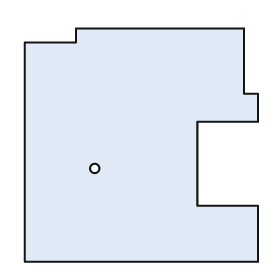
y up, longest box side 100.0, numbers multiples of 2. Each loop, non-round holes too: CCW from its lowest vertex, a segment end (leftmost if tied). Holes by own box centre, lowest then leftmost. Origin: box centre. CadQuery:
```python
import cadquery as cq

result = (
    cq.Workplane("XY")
    .moveTo(-50.0, -50.0)
    .lineTo(50.0, -50.0)
    .lineTo(50.0, -26.0)
    .lineTo(24.0, -26.0)
    .lineTo(24.0, 10.0)
    .lineTo(50.0, 10.0)
    .lineTo(50.0, 22.0)
    .lineTo(44.0, 22.0)
    .lineTo(44.0, 50.0)
    .lineTo(-28.0, 50.0)
    .lineTo(-28.0, 44.0)
    .lineTo(-50.0, 44.0)
    .close()
    .moveTo(-20.0, -10.0)
    .circle(2.0)
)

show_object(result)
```